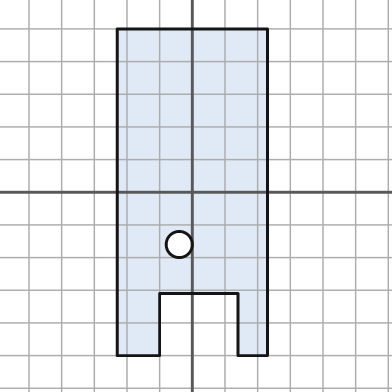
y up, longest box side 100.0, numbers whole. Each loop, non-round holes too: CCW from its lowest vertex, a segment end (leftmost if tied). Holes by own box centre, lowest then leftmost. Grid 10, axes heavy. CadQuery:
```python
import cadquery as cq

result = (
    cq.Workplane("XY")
    .moveTo(-23.0, -50.0)
    .lineTo(-10.0, -50.0)
    .lineTo(-10.0, -31.0)
    .lineTo(14.0, -31.0)
    .lineTo(14.0, -50.0)
    .lineTo(23.0, -50.0)
    .lineTo(23.0, 50.0)
    .lineTo(-23.0, 50.0)
    .close()
    .moveTo(-4.0, -16.0)
    .circle(4.0)
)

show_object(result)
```